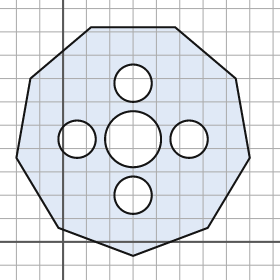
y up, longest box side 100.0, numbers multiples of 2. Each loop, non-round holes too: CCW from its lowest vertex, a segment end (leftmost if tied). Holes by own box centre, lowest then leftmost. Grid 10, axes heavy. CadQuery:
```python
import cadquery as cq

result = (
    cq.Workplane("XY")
    .moveTo(30.0, -6.0)
    .lineTo(62.0, 6.0)
    .lineTo(80.0, 36.0)
    .lineTo(74.0, 70.0)
    .lineTo(48.0, 92.0)
    .lineTo(12.0, 92.0)
    .lineTo(-14.0, 70.0)
    .lineTo(-20.0, 36.0)
    .lineTo(-2.0, 6.0)
    .close()
    .moveTo(30.0, 20.0)
    .circle(8.0)
    .moveTo(6.0, 44.0)
    .circle(8.0)
    .moveTo(30.0, 44.0)
    .circle(12.0)
    .moveTo(54.0, 44.0)
    .circle(8.0)
    .moveTo(30.0, 68.0)
    .circle(8.0)
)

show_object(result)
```